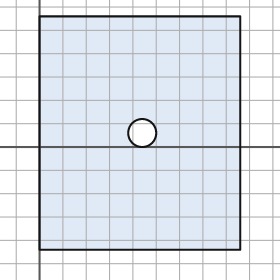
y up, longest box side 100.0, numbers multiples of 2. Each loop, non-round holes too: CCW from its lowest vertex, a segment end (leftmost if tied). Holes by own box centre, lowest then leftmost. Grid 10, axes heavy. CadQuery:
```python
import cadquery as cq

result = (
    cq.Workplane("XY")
    .moveTo(0.0, -44.0)
    .lineTo(86.0, -44.0)
    .lineTo(86.0, 56.0)
    .lineTo(0.0, 56.0)
    .close()
    .moveTo(44.0, 6.0)
    .circle(6.0)
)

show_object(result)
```